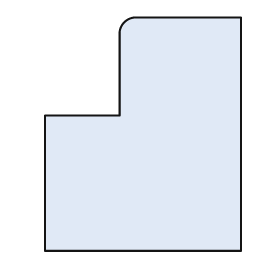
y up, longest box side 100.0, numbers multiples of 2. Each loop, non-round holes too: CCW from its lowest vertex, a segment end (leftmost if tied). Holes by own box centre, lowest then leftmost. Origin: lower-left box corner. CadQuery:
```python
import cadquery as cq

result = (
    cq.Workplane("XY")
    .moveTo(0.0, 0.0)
    .lineTo(84.0, 0.0)
    .lineTo(84.0, 100.0)
    .lineTo(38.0, 100.0)
    .threePointArc((34.0, 98.0), (32.0, 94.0))
    .lineTo(32.0, 58.0)
    .lineTo(0.0, 58.0)
    .close()
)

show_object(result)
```